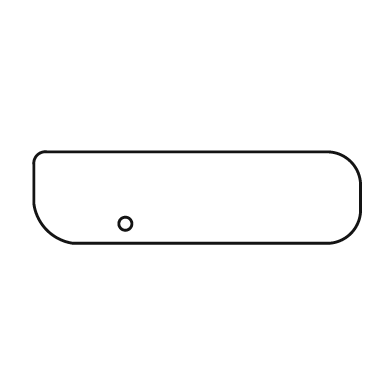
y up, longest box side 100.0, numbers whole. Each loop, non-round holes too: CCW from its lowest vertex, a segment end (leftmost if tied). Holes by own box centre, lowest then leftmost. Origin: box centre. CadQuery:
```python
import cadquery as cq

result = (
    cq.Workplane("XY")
    .moveTo(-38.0, -14.0)
    .lineTo(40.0, -14.0)
    .threePointArc((47.0, -11.0), (50.0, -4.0))
    .lineTo(50.0, 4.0)
    .threePointArc((47.0, 11.0), (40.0, 14.0))
    .lineTo(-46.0, 14.0)
    .threePointArc((-49.0, 13.0), (-50.0, 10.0))
    .lineTo(-50.0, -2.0)
    .threePointArc((-46.0, -10.0), (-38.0, -14.0))
    .close()
    .moveTo(-22.0, -8.0)
    .circle(2.0)
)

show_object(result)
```